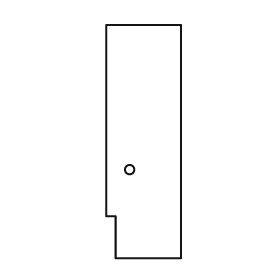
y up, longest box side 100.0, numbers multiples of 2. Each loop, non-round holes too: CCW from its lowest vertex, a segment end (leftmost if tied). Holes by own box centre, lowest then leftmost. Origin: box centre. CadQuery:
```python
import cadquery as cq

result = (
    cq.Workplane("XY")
    .moveTo(-12.0, -50.0)
    .lineTo(16.0, -50.0)
    .lineTo(16.0, 50.0)
    .lineTo(-16.0, 50.0)
    .lineTo(-16.0, -32.0)
    .lineTo(-12.0, -32.0)
    .close()
    .moveTo(-6.0, -12.0)
    .circle(2.0)
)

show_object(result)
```